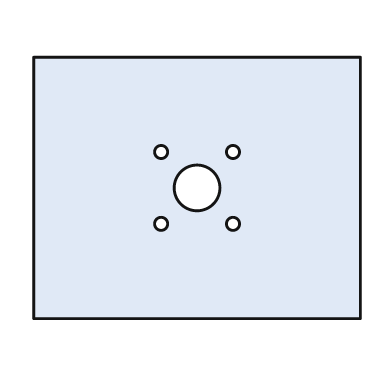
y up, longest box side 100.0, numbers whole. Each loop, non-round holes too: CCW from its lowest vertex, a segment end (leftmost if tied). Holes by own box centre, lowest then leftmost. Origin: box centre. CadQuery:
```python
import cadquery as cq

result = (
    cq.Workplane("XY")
    .moveTo(-50.0, -40.0)
    .lineTo(50.0, -40.0)
    .lineTo(50.0, 40.0)
    .lineTo(-50.0, 40.0)
    .close()
    .moveTo(-11.0, -11.0)
    .circle(2.0)
    .moveTo(11.0, -11.0)
    .circle(2.0)
    .moveTo(0.0, 0.0)
    .circle(7.0)
    .moveTo(-11.0, 11.0)
    .circle(2.0)
    .moveTo(11.0, 11.0)
    .circle(2.0)
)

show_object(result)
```